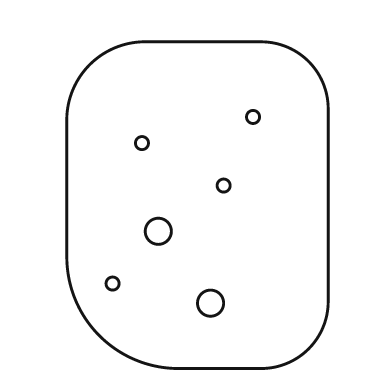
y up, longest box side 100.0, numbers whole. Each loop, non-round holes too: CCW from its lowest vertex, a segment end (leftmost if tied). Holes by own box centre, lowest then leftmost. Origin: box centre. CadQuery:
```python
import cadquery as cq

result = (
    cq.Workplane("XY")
    .moveTo(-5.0, -50.0)
    .lineTo(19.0, -50.0)
    .threePointArc((34.0, -44.0), (40.0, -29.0))
    .lineTo(40.0, 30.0)
    .threePointArc((34.0, 44.0), (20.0, 50.0))
    .lineTo(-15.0, 50.0)
    .threePointArc((-33.0, 43.0), (-40.0, 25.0))
    .lineTo(-40.0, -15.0)
    .threePointArc((-30.0, -40.0), (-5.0, -50.0))
    .close()
    .moveTo(4.0, -30.0)
    .circle(4.0)
    .moveTo(-26.0, -24.0)
    .circle(2.0)
    .moveTo(-12.0, -8.0)
    .circle(4.0)
    .moveTo(8.0, 6.0)
    .circle(2.0)
    .moveTo(-17.0, 19.0)
    .circle(2.0)
    .moveTo(17.0, 27.0)
    .circle(2.0)
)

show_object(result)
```